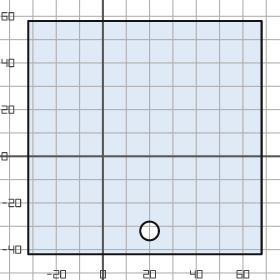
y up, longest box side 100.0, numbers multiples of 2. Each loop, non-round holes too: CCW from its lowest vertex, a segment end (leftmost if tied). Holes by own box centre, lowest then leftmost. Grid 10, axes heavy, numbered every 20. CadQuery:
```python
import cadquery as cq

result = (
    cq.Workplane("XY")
    .moveTo(-32.0, -42.0)
    .lineTo(68.0, -42.0)
    .lineTo(68.0, 58.0)
    .lineTo(-32.0, 58.0)
    .close()
    .moveTo(20.0, -32.0)
    .circle(4.0)
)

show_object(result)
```